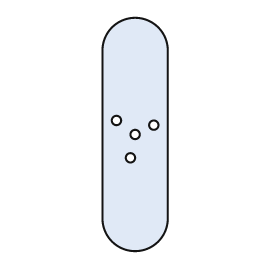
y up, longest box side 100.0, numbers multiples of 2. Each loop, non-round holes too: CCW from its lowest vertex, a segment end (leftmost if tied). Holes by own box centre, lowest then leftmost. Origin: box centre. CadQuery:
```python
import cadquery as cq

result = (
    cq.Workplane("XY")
    .moveTo(-14.0, -36.0)
    .threePointArc((0.0, -50.0), (14.0, -36.0))
    .lineTo(14.0, 36.0)
    .threePointArc((0.0, 50.0), (-14.0, 36.0))
    .close()
    .moveTo(-2.0, -10.0)
    .circle(2.0)
    .moveTo(0.0, 0.0)
    .circle(2.0)
    .moveTo(8.0, 4.0)
    .circle(2.0)
    .moveTo(-8.0, 6.0)
    .circle(2.0)
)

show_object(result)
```